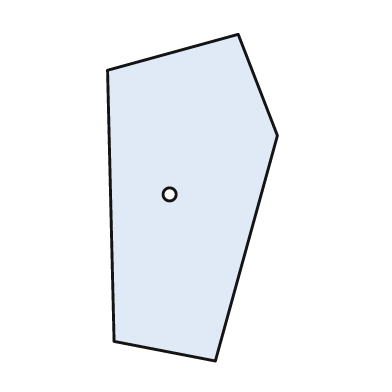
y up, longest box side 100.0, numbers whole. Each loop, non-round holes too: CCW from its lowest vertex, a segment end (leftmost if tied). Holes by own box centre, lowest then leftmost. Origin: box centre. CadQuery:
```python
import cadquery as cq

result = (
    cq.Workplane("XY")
    .moveTo(7.0, -50.0)
    .lineTo(26.0, 19.0)
    .lineTo(14.0, 50.0)
    .lineTo(-26.0, 39.0)
    .lineTo(-24.0, -44.0)
    .close()
    .moveTo(-7.0, 1.0)
    .circle(2.0)
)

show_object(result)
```